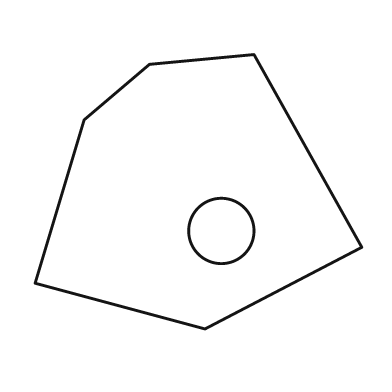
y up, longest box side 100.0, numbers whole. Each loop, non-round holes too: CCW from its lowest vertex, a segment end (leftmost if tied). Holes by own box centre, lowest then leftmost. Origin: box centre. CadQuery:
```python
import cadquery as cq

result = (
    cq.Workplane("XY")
    .moveTo(2.0, -42.0)
    .lineTo(50.0, -17.0)
    .lineTo(17.0, 42.0)
    .lineTo(-15.0, 39.0)
    .lineTo(-35.0, 22.0)
    .lineTo(-50.0, -28.0)
    .close()
    .moveTo(7.0, -12.0)
    .circle(10.0)
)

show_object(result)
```